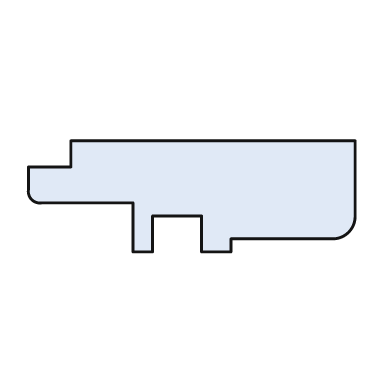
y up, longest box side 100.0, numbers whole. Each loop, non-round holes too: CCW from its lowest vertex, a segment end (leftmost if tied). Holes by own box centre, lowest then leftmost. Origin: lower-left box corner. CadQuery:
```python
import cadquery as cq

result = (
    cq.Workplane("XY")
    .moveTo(32.0, 0.0)
    .lineTo(38.0, 0.0)
    .lineTo(38.0, 11.0)
    .lineTo(53.0, 11.0)
    .lineTo(53.0, 0.0)
    .lineTo(62.0, 0.0)
    .lineTo(62.0, 4.0)
    .lineTo(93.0, 4.0)
    .threePointArc((98.0, 6.0), (100.0, 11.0))
    .lineTo(100.0, 34.0)
    .lineTo(13.0, 34.0)
    .lineTo(13.0, 26.0)
    .lineTo(0.0, 26.0)
    .lineTo(0.0, 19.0)
    .threePointArc((1.0, 16.0), (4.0, 15.0))
    .lineTo(32.0, 15.0)
    .close()
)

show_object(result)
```